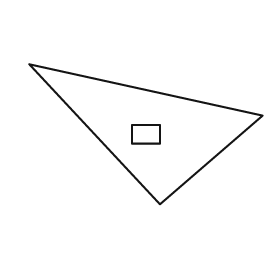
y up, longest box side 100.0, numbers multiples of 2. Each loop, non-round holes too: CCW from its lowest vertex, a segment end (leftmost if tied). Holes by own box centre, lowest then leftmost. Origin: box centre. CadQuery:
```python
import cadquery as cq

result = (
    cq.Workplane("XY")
    .moveTo(6.0, -30.0)
    .lineTo(50.0, 8.0)
    .lineTo(-50.0, 30.0)
    .close()
    .moveTo(-6.0, -4.0)
    .lineTo(6.0, -4.0)
    .lineTo(6.0, 4.0)
    .lineTo(-6.0, 4.0)
    .close()
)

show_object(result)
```